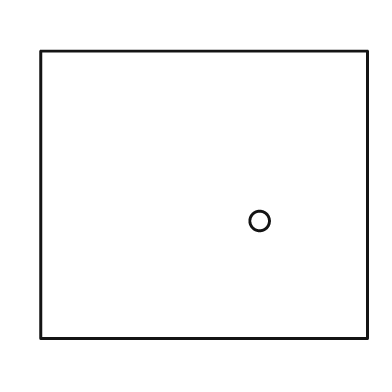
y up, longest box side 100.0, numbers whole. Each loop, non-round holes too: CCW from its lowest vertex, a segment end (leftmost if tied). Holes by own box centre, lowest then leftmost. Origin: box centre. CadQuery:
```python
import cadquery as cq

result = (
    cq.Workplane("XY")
    .moveTo(-50.0, -44.0)
    .lineTo(50.0, -44.0)
    .lineTo(50.0, 44.0)
    .lineTo(-50.0, 44.0)
    .close()
    .moveTo(17.0, -8.0)
    .circle(3.0)
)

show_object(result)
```